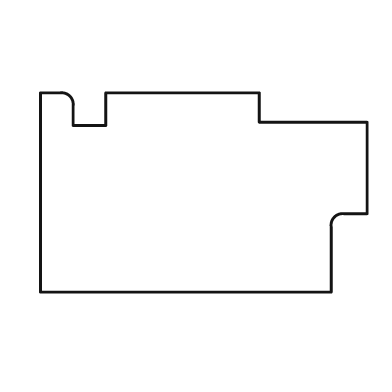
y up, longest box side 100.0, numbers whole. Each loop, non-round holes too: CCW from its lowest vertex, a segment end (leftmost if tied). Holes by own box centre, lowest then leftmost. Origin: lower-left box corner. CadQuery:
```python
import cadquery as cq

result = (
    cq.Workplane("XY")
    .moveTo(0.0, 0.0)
    .lineTo(89.0, 0.0)
    .lineTo(89.0, 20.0)
    .threePointArc((90.0, 23.0), (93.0, 24.0))
    .lineTo(100.0, 24.0)
    .lineTo(100.0, 52.0)
    .lineTo(67.0, 52.0)
    .lineTo(67.0, 61.0)
    .lineTo(20.0, 61.0)
    .lineTo(20.0, 51.0)
    .lineTo(10.0, 51.0)
    .lineTo(10.0, 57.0)
    .threePointArc((9.0, 60.0), (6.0, 61.0))
    .lineTo(0.0, 61.0)
    .close()
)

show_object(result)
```